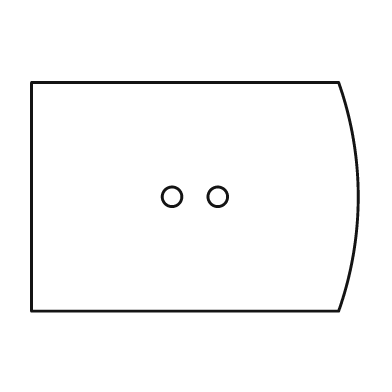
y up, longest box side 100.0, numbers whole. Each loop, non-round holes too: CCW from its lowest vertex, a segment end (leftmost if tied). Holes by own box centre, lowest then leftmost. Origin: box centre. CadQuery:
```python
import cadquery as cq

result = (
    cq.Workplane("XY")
    .moveTo(-50.0, -35.0)
    .lineTo(44.0, -35.0)
    .threePointArc((50.0, 0.0), (44.0, 35.0))
    .lineTo(-50.0, 35.0)
    .close()
    .moveTo(-7.0, 0.0)
    .circle(3.0)
    .moveTo(7.0, 0.0)
    .circle(3.0)
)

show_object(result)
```